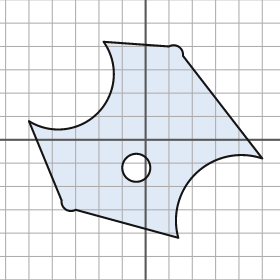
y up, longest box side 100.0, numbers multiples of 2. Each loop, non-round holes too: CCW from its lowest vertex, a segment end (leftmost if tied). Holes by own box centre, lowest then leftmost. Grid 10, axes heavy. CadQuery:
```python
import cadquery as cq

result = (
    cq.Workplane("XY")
    .moveTo(14.0, -42.0)
    .threePointArc((22.0, -14.0), (50.0, -8.0))
    .lineTo(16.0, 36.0)
    .threePointArc((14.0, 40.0), (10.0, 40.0))
    .lineTo(-18.0, 42.0)
    .threePointArc((-20.0, 12.0), (-50.0, 8.0))
    .lineTo(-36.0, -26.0)
    .threePointArc((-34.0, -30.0), (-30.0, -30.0))
    .close()
    .moveTo(-4.0, -12.0)
    .circle(6.0)
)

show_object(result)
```